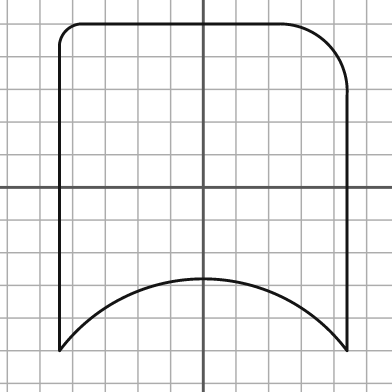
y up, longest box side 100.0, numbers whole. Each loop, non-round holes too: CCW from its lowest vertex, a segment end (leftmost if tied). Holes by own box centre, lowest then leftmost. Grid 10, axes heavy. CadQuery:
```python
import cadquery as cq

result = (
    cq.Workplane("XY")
    .moveTo(-44.0, -50.0)
    .threePointArc((0.0, -28.0), (44.0, -50.0))
    .lineTo(44.0, 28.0)
    .threePointArc((38.0, 44.0), (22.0, 50.0))
    .lineTo(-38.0, 50.0)
    .threePointArc((-42.0, 48.0), (-44.0, 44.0))
    .close()
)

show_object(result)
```